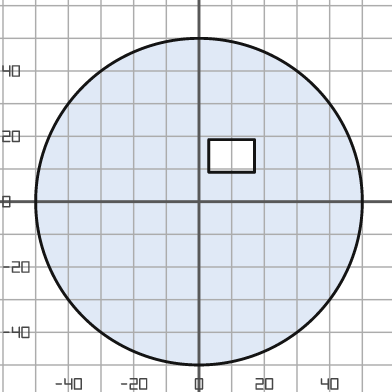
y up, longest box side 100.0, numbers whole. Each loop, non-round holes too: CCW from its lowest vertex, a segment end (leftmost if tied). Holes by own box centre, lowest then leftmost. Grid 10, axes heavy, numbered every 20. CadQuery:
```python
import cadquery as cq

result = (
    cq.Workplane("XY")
    .moveTo(0.0, 0.0)
    .circle(50.0)
    .moveTo(3.0, 9.0)
    .lineTo(17.0, 9.0)
    .lineTo(17.0, 19.0)
    .lineTo(3.0, 19.0)
    .close()
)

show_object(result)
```